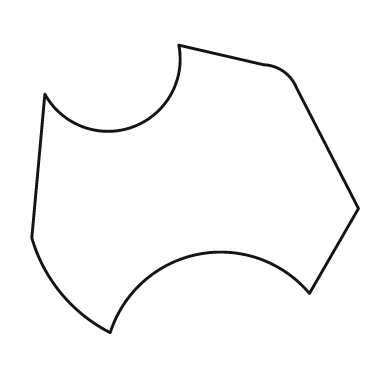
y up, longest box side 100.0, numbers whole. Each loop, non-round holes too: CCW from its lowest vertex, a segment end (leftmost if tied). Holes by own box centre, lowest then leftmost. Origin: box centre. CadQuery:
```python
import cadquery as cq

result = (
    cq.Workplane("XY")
    .moveTo(-26.0, -44.0)
    .threePointArc((1.0, -20.0), (35.0, -32.0))
    .lineTo(50.0, -6.0)
    .lineTo(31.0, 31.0)
    .threePointArc((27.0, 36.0), (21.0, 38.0))
    .lineTo(-5.0, 44.0)
    .threePointArc((-19.0, 19.0), (-46.0, 29.0))
    .lineTo(-50.0, -15.0)
    .threePointArc((-41.0, -32.0), (-26.0, -44.0))
    .close()
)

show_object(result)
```